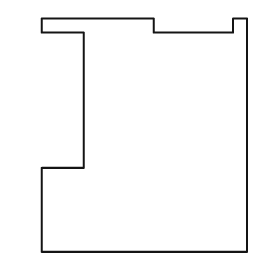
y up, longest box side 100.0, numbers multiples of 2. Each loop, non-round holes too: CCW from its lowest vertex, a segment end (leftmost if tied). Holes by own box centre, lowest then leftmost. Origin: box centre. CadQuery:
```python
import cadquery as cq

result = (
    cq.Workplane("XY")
    .moveTo(-44.0, -50.0)
    .lineTo(44.0, -50.0)
    .lineTo(44.0, 50.0)
    .lineTo(38.0, 50.0)
    .lineTo(38.0, 44.0)
    .lineTo(4.0, 44.0)
    .lineTo(4.0, 50.0)
    .lineTo(-44.0, 50.0)
    .lineTo(-44.0, 44.0)
    .lineTo(-26.0, 44.0)
    .lineTo(-26.0, -14.0)
    .lineTo(-44.0, -14.0)
    .close()
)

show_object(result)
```